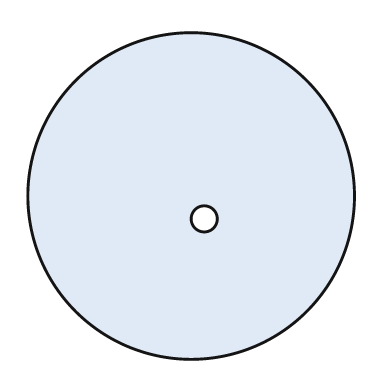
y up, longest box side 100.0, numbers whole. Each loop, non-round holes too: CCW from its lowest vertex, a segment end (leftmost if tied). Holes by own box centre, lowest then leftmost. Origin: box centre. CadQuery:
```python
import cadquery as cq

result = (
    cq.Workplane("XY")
    .moveTo(0.0, 0.0)
    .circle(50.0)
    .moveTo(4.0, -7.0)
    .circle(4.0)
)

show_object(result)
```